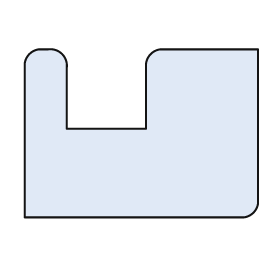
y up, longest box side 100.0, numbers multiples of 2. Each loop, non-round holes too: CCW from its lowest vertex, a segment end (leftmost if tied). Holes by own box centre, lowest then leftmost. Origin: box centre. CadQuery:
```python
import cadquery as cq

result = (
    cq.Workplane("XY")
    .moveTo(-50.0, -36.0)
    .lineTo(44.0, -36.0)
    .threePointArc((48.0, -34.0), (50.0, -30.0))
    .lineTo(50.0, 36.0)
    .lineTo(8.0, 36.0)
    .threePointArc((4.0, 34.0), (2.0, 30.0))
    .lineTo(2.0, 2.0)
    .lineTo(-32.0, 2.0)
    .lineTo(-32.0, 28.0)
    .threePointArc((-34.0, 34.0), (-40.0, 36.0))
    .lineTo(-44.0, 36.0)
    .threePointArc((-48.0, 34.0), (-50.0, 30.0))
    .close()
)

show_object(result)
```